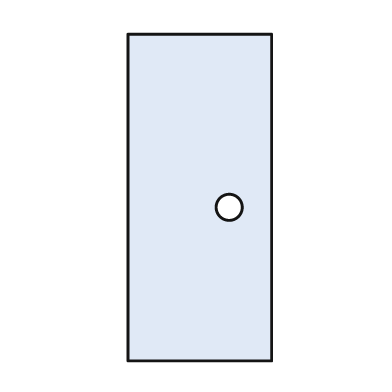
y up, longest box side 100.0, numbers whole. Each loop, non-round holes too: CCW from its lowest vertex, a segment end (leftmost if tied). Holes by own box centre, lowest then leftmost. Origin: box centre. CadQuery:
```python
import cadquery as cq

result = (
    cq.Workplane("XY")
    .moveTo(-22.0, -50.0)
    .lineTo(22.0, -50.0)
    .lineTo(22.0, 50.0)
    .lineTo(-22.0, 50.0)
    .close()
    .moveTo(9.0, -3.0)
    .circle(4.0)
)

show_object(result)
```